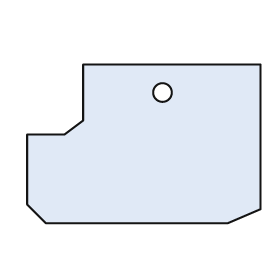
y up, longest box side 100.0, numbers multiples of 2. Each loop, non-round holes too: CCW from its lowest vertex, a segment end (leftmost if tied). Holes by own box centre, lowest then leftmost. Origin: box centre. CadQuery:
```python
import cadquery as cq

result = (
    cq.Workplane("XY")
    .moveTo(-42.0, -34.0)
    .lineTo(36.0, -34.0)
    .lineTo(50.0, -28.0)
    .lineTo(50.0, 34.0)
    .lineTo(-26.0, 34.0)
    .lineTo(-26.0, 10.0)
    .lineTo(-34.0, 4.0)
    .lineTo(-50.0, 4.0)
    .lineTo(-50.0, -26.0)
    .close()
    .moveTo(8.0, 22.0)
    .circle(4.0)
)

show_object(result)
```